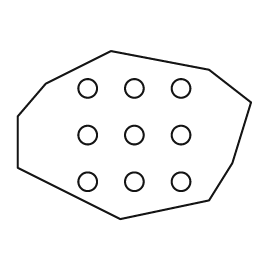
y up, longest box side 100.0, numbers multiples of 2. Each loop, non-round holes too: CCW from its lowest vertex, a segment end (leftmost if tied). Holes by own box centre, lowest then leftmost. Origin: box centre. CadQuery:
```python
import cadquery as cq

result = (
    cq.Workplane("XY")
    .moveTo(-6.0, -36.0)
    .lineTo(32.0, -28.0)
    .lineTo(42.0, -12.0)
    .lineTo(50.0, 14.0)
    .lineTo(32.0, 28.0)
    .lineTo(-10.0, 36.0)
    .lineTo(-38.0, 22.0)
    .lineTo(-50.0, 8.0)
    .lineTo(-50.0, -14.0)
    .close()
    .moveTo(-20.0, -20.0)
    .circle(4.0)
    .moveTo(0.0, -20.0)
    .circle(4.0)
    .moveTo(20.0, -20.0)
    .circle(4.0)
    .moveTo(-20.0, 0.0)
    .circle(4.0)
    .moveTo(0.0, 0.0)
    .circle(4.0)
    .moveTo(20.0, 0.0)
    .circle(4.0)
    .moveTo(-20.0, 20.0)
    .circle(4.0)
    .moveTo(0.0, 20.0)
    .circle(4.0)
    .moveTo(20.0, 20.0)
    .circle(4.0)
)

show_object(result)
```